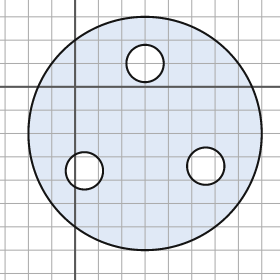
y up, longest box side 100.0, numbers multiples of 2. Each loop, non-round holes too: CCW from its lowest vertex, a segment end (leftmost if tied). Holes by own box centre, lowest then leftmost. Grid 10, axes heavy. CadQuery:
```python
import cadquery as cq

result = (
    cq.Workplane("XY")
    .moveTo(30.0, -20.0)
    .circle(50.0)
    .moveTo(4.0, -36.0)
    .circle(8.0)
    .moveTo(56.0, -34.0)
    .circle(8.0)
    .moveTo(30.0, 10.0)
    .circle(8.0)
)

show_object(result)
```